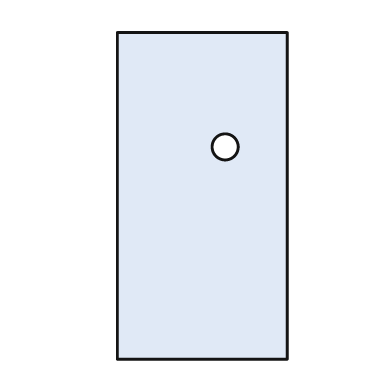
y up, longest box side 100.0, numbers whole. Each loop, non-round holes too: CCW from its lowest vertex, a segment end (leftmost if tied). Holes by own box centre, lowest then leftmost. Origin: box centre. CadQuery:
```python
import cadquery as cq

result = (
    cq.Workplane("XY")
    .moveTo(-26.0, -50.0)
    .lineTo(26.0, -50.0)
    .lineTo(26.0, 50.0)
    .lineTo(-26.0, 50.0)
    .close()
    .moveTo(7.0, 15.0)
    .circle(4.0)
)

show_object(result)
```